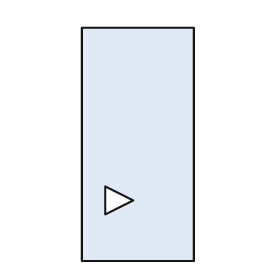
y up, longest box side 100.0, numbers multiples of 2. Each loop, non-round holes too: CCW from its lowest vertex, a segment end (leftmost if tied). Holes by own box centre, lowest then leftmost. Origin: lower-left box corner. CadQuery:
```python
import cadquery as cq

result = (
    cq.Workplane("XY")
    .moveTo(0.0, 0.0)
    .lineTo(48.0, 0.0)
    .lineTo(48.0, 100.0)
    .lineTo(0.0, 100.0)
    .close()
    .moveTo(10.0, 20.0)
    .lineTo(22.0, 26.0)
    .lineTo(10.0, 32.0)
    .close()
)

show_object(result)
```